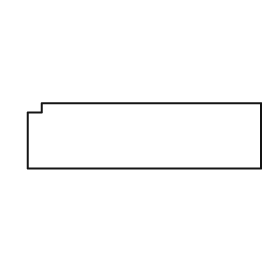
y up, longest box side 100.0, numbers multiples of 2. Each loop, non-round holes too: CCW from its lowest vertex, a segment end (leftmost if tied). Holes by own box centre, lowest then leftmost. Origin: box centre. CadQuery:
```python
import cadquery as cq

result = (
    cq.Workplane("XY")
    .moveTo(-50.0, -14.0)
    .lineTo(50.0, -14.0)
    .lineTo(50.0, 14.0)
    .lineTo(-44.0, 14.0)
    .lineTo(-44.0, 10.0)
    .lineTo(-50.0, 10.0)
    .close()
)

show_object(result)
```